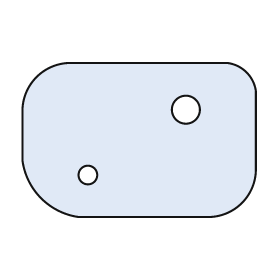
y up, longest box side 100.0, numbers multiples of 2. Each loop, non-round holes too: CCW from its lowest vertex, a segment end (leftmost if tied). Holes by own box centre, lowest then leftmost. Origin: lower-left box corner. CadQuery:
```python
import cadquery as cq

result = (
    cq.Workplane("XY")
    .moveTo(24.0, 0.0)
    .lineTo(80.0, 0.0)
    .threePointArc((94.0, 6.0), (100.0, 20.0))
    .lineTo(100.0, 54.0)
    .threePointArc((96.0, 62.0), (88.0, 66.0))
    .lineTo(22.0, 66.0)
    .threePointArc((6.0, 60.0), (0.0, 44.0))
    .lineTo(0.0, 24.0)
    .threePointArc((8.0, 8.0), (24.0, 0.0))
    .close()
    .moveTo(28.0, 18.0)
    .circle(4.0)
    .moveTo(70.0, 46.0)
    .circle(6.0)
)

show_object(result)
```